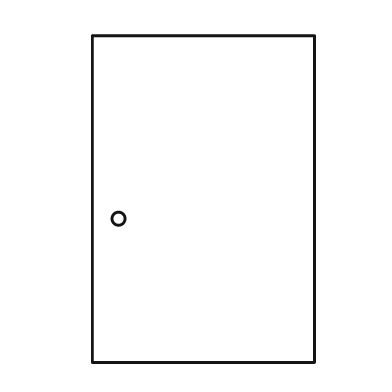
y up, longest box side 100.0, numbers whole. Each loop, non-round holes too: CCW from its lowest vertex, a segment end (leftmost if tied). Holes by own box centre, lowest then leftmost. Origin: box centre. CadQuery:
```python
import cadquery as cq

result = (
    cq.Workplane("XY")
    .moveTo(-34.0, -50.0)
    .lineTo(34.0, -50.0)
    .lineTo(34.0, 50.0)
    .lineTo(-34.0, 50.0)
    .close()
    .moveTo(-26.0, -6.0)
    .circle(2.0)
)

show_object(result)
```